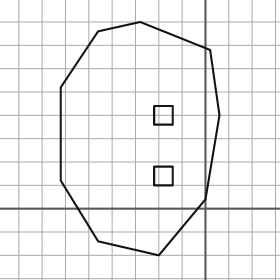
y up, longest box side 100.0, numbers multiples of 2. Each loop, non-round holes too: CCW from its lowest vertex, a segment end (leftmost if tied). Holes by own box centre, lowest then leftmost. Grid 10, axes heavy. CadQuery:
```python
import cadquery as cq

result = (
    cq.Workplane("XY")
    .moveTo(-20.0, -20.0)
    .lineTo(0.0, 4.0)
    .lineTo(6.0, 40.0)
    .lineTo(2.0, 68.0)
    .lineTo(-28.0, 80.0)
    .lineTo(-46.0, 76.0)
    .lineTo(-62.0, 52.0)
    .lineTo(-62.0, 12.0)
    .lineTo(-46.0, -14.0)
    .close()
    .moveTo(-22.0, 10.0)
    .lineTo(-14.0, 10.0)
    .lineTo(-14.0, 18.0)
    .lineTo(-22.0, 18.0)
    .close()
    .moveTo(-22.0, 36.0)
    .lineTo(-14.0, 36.0)
    .lineTo(-14.0, 44.0)
    .lineTo(-22.0, 44.0)
    .close()
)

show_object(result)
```